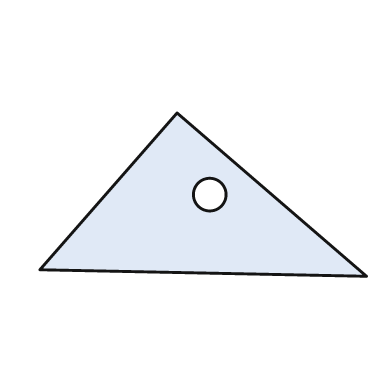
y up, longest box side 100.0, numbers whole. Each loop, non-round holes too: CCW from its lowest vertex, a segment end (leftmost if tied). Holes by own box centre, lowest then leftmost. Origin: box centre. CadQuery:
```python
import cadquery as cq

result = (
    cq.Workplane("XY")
    .moveTo(50.0, -25.0)
    .lineTo(-8.0, 25.0)
    .lineTo(-50.0, -23.0)
    .close()
    .moveTo(2.0, 0.0)
    .circle(5.0)
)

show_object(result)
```